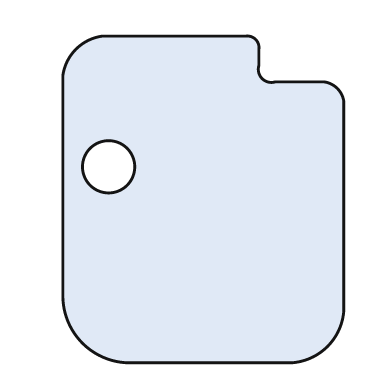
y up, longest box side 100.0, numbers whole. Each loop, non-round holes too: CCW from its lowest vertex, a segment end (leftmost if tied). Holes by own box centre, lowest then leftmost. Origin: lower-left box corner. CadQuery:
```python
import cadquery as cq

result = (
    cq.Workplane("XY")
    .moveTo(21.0, 0.0)
    .lineTo(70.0, 0.0)
    .threePointArc((81.0, 5.0), (86.0, 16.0))
    .lineTo(86.0, 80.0)
    .threePointArc((84.0, 84.0), (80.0, 86.0))
    .lineTo(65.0, 86.0)
    .threePointArc((61.0, 87.0), (60.0, 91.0))
    .lineTo(60.0, 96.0)
    .threePointArc((59.0, 99.0), (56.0, 100.0))
    .lineTo(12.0, 100.0)
    .threePointArc((4.0, 96.0), (0.0, 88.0))
    .lineTo(0.0, 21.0)
    .threePointArc((6.0, 6.0), (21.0, 0.0))
    .close()
    .moveTo(14.0, 60.0)
    .circle(8.0)
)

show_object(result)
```